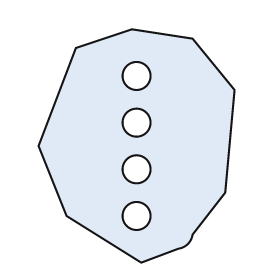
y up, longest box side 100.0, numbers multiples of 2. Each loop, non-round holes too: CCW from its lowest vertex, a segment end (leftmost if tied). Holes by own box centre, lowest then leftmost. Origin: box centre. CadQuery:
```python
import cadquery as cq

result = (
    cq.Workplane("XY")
    .moveTo(2.0, -50.0)
    .lineTo(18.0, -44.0)
    .threePointArc((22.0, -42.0), (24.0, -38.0))
    .lineTo(38.0, -20.0)
    .lineTo(42.0, 24.0)
    .lineTo(24.0, 46.0)
    .lineTo(-2.0, 50.0)
    .lineTo(-26.0, 42.0)
    .lineTo(-42.0, 0.0)
    .lineTo(-30.0, -30.0)
    .close()
    .moveTo(0.0, -30.0)
    .circle(6.0)
    .moveTo(0.0, -10.0)
    .circle(6.0)
    .moveTo(0.0, 10.0)
    .circle(6.0)
    .moveTo(0.0, 30.0)
    .circle(6.0)
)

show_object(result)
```